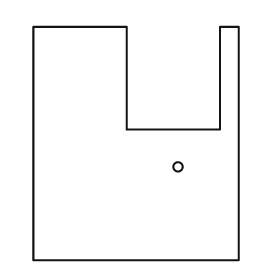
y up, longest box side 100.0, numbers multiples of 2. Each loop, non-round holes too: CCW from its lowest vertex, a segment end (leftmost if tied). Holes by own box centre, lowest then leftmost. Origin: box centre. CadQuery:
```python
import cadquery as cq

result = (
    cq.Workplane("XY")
    .moveTo(-44.0, -50.0)
    .lineTo(44.0, -50.0)
    .lineTo(44.0, 50.0)
    .lineTo(36.0, 50.0)
    .lineTo(36.0, 6.0)
    .lineTo(-4.0, 6.0)
    .lineTo(-4.0, 50.0)
    .lineTo(-44.0, 50.0)
    .close()
    .moveTo(18.0, -10.0)
    .circle(2.0)
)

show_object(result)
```